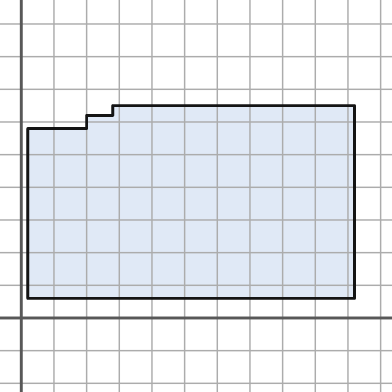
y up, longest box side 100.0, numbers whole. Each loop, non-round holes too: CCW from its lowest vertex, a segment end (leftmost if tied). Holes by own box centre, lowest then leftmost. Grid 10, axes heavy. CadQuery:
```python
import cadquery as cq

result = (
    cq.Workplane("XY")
    .moveTo(2.0, 6.0)
    .lineTo(102.0, 6.0)
    .lineTo(102.0, 65.0)
    .lineTo(28.0, 65.0)
    .lineTo(28.0, 62.0)
    .lineTo(20.0, 62.0)
    .lineTo(20.0, 58.0)
    .lineTo(2.0, 58.0)
    .close()
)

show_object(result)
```